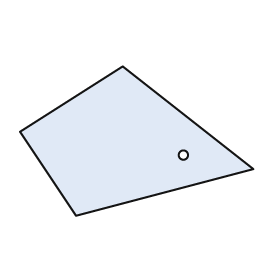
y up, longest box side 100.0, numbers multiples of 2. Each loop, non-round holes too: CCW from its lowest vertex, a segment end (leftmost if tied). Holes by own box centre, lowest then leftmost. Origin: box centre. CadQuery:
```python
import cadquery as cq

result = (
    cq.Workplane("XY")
    .moveTo(-26.0, -32.0)
    .lineTo(50.0, -12.0)
    .lineTo(-6.0, 32.0)
    .lineTo(-50.0, 4.0)
    .close()
    .moveTo(20.0, -6.0)
    .circle(2.0)
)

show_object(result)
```